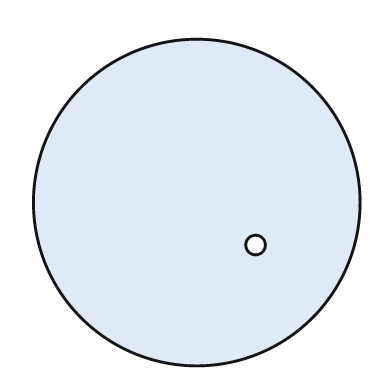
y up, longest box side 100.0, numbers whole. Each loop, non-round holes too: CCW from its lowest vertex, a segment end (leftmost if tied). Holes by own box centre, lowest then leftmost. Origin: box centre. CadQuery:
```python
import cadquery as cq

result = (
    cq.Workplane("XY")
    .moveTo(0.0, 0.0)
    .circle(50.0)
    .moveTo(18.0, -13.0)
    .circle(3.0)
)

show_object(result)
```